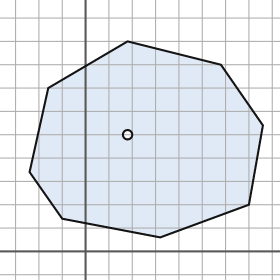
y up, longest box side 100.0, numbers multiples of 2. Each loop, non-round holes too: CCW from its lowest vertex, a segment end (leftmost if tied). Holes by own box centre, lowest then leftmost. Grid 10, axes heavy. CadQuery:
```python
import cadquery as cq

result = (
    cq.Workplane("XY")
    .moveTo(32.0, 6.0)
    .lineTo(70.0, 20.0)
    .lineTo(76.0, 54.0)
    .lineTo(58.0, 80.0)
    .lineTo(18.0, 90.0)
    .lineTo(-16.0, 70.0)
    .lineTo(-24.0, 34.0)
    .lineTo(-10.0, 14.0)
    .close()
    .moveTo(18.0, 50.0)
    .circle(2.0)
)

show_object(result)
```